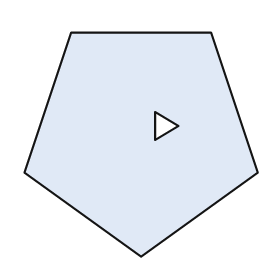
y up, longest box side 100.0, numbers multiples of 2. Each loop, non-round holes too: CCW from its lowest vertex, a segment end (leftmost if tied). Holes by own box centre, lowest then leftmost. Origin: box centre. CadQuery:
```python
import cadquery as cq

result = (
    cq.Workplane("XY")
    .moveTo(0.0, -48.0)
    .lineTo(50.0, -12.0)
    .lineTo(30.0, 48.0)
    .lineTo(-30.0, 48.0)
    .lineTo(-50.0, -12.0)
    .close()
    .moveTo(6.0, 2.0)
    .lineTo(16.0, 8.0)
    .lineTo(6.0, 14.0)
    .close()
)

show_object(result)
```